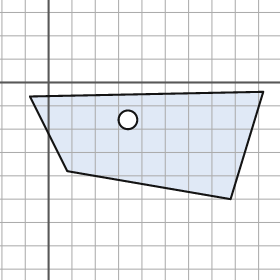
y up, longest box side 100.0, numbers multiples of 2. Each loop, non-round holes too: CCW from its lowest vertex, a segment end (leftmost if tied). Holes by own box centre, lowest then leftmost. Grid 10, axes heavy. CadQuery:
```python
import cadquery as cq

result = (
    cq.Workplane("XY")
    .moveTo(78.0, -50.0)
    .lineTo(92.0, -4.0)
    .lineTo(-8.0, -6.0)
    .lineTo(8.0, -38.0)
    .close()
    .moveTo(34.0, -16.0)
    .circle(4.0)
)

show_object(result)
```